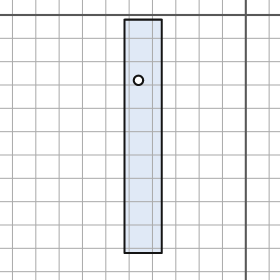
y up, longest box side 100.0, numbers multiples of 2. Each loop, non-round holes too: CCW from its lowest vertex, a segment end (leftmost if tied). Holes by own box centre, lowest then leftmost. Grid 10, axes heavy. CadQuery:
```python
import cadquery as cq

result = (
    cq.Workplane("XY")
    .moveTo(-52.0, -102.0)
    .lineTo(-36.0, -102.0)
    .lineTo(-36.0, -2.0)
    .lineTo(-52.0, -2.0)
    .close()
    .moveTo(-46.0, -28.0)
    .circle(2.0)
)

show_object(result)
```